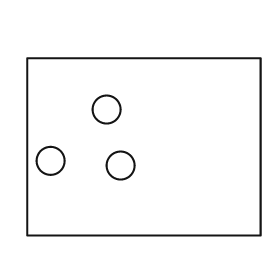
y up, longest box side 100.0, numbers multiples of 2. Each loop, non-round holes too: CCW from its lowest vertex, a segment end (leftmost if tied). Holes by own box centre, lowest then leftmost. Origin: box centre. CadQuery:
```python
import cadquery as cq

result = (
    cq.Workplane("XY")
    .moveTo(-50.0, -38.0)
    .lineTo(50.0, -38.0)
    .lineTo(50.0, 38.0)
    .lineTo(-50.0, 38.0)
    .close()
    .moveTo(-10.0, -8.0)
    .circle(6.0)
    .moveTo(-40.0, -6.0)
    .circle(6.0)
    .moveTo(-16.0, 16.0)
    .circle(6.0)
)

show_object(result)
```